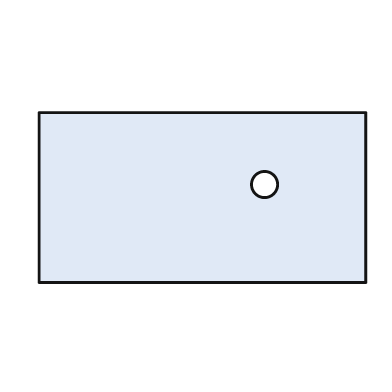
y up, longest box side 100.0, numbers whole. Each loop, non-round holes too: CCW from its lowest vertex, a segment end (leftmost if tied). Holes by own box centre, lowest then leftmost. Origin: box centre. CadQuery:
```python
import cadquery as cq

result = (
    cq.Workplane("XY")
    .moveTo(-50.0, -26.0)
    .lineTo(50.0, -26.0)
    .lineTo(50.0, 26.0)
    .lineTo(-50.0, 26.0)
    .close()
    .moveTo(19.0, 4.0)
    .circle(4.0)
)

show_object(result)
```